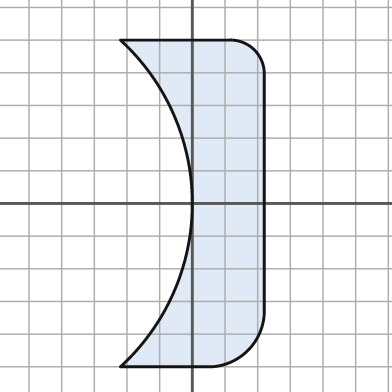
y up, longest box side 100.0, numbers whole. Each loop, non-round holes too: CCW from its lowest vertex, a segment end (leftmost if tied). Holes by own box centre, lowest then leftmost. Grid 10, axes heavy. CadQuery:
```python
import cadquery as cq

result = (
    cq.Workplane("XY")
    .moveTo(-22.0, -50.0)
    .lineTo(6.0, -50.0)
    .threePointArc((17.0, -45.0), (22.0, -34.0))
    .lineTo(22.0, 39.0)
    .threePointArc((19.0, 47.0), (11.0, 50.0))
    .lineTo(-22.0, 50.0)
    .threePointArc((0.0, 0.0), (-22.0, -50.0))
    .close()
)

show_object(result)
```